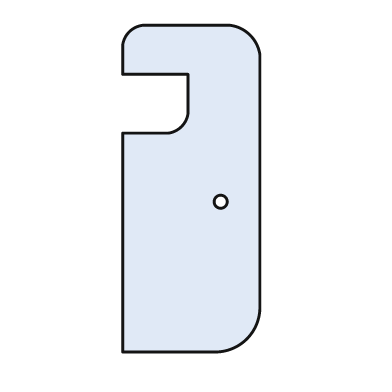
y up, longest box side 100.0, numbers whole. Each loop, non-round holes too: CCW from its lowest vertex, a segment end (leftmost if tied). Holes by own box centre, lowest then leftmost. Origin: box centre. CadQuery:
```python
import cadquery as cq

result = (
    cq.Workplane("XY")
    .moveTo(-21.0, -50.0)
    .lineTo(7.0, -50.0)
    .threePointArc((17.0, -46.0), (21.0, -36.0))
    .lineTo(21.0, 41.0)
    .threePointArc((18.0, 47.0), (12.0, 50.0))
    .lineTo(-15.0, 50.0)
    .threePointArc((-19.0, 48.0), (-21.0, 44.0))
    .lineTo(-21.0, 35.0)
    .lineTo(-1.0, 35.0)
    .lineTo(-1.0, 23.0)
    .threePointArc((-3.0, 19.0), (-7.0, 17.0))
    .lineTo(-21.0, 17.0)
    .close()
    .moveTo(9.0, -4.0)
    .circle(2.0)
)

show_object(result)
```